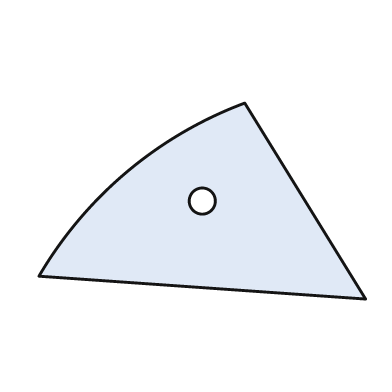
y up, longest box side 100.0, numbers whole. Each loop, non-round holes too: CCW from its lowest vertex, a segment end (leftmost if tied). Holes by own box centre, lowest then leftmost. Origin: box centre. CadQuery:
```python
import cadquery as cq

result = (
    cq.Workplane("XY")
    .moveTo(50.0, -30.0)
    .lineTo(13.0, 30.0)
    .threePointArc((-23.0, 9.0), (-50.0, -23.0))
    .close()
    .moveTo(0.0, 0.0)
    .circle(4.0)
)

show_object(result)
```